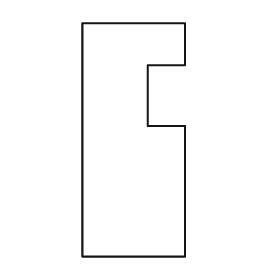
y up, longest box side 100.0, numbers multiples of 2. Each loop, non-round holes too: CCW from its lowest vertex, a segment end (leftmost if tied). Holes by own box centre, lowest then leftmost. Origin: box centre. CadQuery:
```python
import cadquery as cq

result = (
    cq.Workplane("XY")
    .moveTo(-22.0, -50.0)
    .lineTo(22.0, -50.0)
    .lineTo(22.0, 6.0)
    .lineTo(6.0, 6.0)
    .lineTo(6.0, 32.0)
    .lineTo(22.0, 32.0)
    .lineTo(22.0, 50.0)
    .lineTo(-22.0, 50.0)
    .close()
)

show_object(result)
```